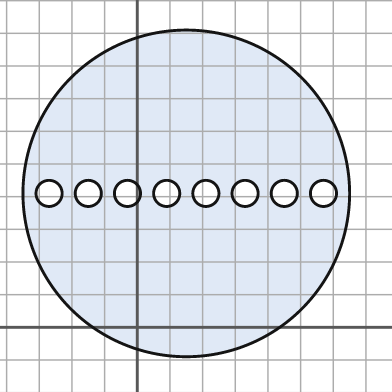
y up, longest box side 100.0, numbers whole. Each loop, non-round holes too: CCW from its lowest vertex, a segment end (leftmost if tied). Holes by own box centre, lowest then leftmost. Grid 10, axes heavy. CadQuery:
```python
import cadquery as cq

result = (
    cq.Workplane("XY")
    .moveTo(15.0, 41.0)
    .circle(50.0)
    .moveTo(-27.0, 41.0)
    .circle(4.0)
    .moveTo(-15.0, 41.0)
    .circle(4.0)
    .moveTo(-3.0, 41.0)
    .circle(4.0)
    .moveTo(9.0, 41.0)
    .circle(4.0)
    .moveTo(21.0, 41.0)
    .circle(4.0)
    .moveTo(33.0, 41.0)
    .circle(4.0)
    .moveTo(45.0, 41.0)
    .circle(4.0)
    .moveTo(57.0, 41.0)
    .circle(4.0)
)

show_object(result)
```